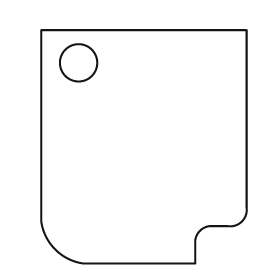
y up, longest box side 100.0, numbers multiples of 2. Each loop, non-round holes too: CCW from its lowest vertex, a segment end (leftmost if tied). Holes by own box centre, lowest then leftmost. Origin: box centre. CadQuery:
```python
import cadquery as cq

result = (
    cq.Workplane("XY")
    .moveTo(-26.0, -50.0)
    .lineTo(22.0, -50.0)
    .lineTo(22.0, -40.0)
    .threePointArc((24.0, -36.0), (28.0, -34.0))
    .lineTo(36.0, -34.0)
    .threePointArc((42.0, -32.0), (44.0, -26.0))
    .lineTo(44.0, 50.0)
    .lineTo(-44.0, 50.0)
    .lineTo(-44.0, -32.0)
    .threePointArc((-38.0, -44.0), (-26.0, -50.0))
    .close()
    .moveTo(-28.0, 36.0)
    .circle(8.0)
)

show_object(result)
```